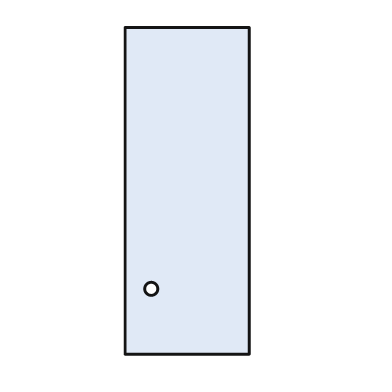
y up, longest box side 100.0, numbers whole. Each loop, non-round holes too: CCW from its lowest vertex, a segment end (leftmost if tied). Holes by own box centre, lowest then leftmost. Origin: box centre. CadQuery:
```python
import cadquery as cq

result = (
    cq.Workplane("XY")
    .moveTo(-19.0, -50.0)
    .lineTo(19.0, -50.0)
    .lineTo(19.0, 50.0)
    .lineTo(-19.0, 50.0)
    .close()
    .moveTo(-11.0, -30.0)
    .circle(2.0)
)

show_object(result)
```